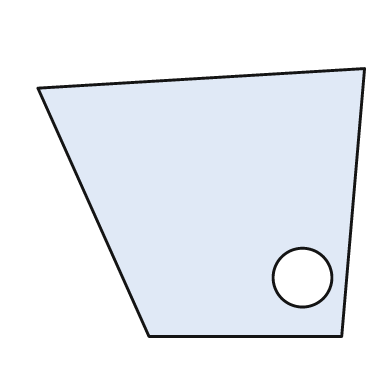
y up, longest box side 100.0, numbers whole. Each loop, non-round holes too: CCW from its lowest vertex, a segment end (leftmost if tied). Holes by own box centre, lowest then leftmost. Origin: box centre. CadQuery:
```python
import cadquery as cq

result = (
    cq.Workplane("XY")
    .moveTo(-16.0, -41.0)
    .lineTo(43.0, -41.0)
    .lineTo(50.0, 41.0)
    .lineTo(-50.0, 35.0)
    .close()
    .moveTo(31.0, -23.0)
    .circle(9.0)
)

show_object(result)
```